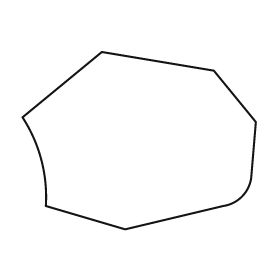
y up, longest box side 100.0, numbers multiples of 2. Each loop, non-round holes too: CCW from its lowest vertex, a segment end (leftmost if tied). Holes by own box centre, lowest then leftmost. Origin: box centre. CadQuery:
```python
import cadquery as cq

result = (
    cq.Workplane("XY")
    .moveTo(-6.0, -38.0)
    .lineTo(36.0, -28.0)
    .threePointArc((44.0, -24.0), (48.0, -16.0))
    .lineTo(50.0, 8.0)
    .lineTo(32.0, 30.0)
    .lineTo(-16.0, 38.0)
    .lineTo(-50.0, 10.0)
    .threePointArc((-42.0, -8.0), (-40.0, -28.0))
    .close()
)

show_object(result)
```